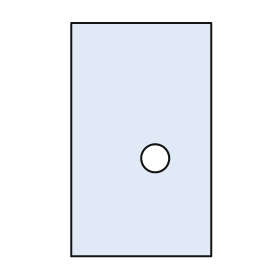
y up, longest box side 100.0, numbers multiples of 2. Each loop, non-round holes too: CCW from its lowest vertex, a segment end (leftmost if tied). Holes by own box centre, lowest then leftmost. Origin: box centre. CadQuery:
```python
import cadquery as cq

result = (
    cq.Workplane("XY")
    .moveTo(-30.0, -50.0)
    .lineTo(30.0, -50.0)
    .lineTo(30.0, 50.0)
    .lineTo(-30.0, 50.0)
    .close()
    .moveTo(6.0, -8.0)
    .circle(6.0)
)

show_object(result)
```